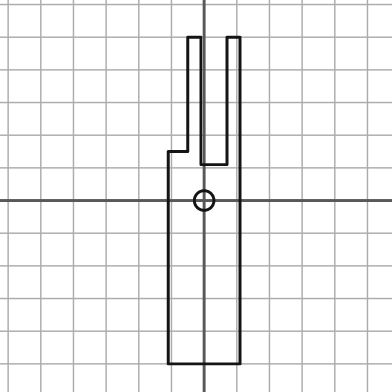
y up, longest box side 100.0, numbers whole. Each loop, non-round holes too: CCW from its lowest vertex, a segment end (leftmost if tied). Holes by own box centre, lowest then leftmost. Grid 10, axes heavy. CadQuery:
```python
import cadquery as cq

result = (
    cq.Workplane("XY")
    .moveTo(-11.0, -50.0)
    .lineTo(11.0, -50.0)
    .lineTo(11.0, 50.0)
    .lineTo(7.0, 50.0)
    .lineTo(7.0, 11.0)
    .lineTo(-1.0, 11.0)
    .lineTo(-1.0, 50.0)
    .lineTo(-5.0, 50.0)
    .lineTo(-5.0, 15.0)
    .lineTo(-11.0, 15.0)
    .close()
    .moveTo(0.0, 0.0)
    .circle(3.0)
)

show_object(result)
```